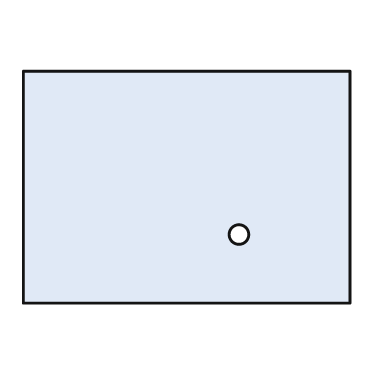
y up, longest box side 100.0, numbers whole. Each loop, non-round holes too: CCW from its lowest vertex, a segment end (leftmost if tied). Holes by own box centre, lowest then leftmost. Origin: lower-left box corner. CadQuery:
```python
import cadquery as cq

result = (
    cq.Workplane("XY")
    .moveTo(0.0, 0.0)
    .lineTo(100.0, 0.0)
    .lineTo(100.0, 71.0)
    .lineTo(0.0, 71.0)
    .close()
    .moveTo(66.0, 21.0)
    .circle(3.0)
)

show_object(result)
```